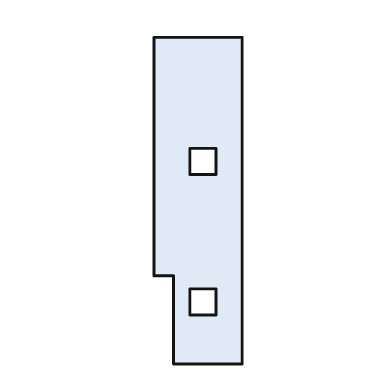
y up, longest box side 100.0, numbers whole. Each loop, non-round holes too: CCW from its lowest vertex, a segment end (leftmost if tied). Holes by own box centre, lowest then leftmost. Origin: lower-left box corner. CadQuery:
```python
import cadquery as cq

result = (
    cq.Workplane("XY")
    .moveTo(6.0, 0.0)
    .lineTo(27.0, 0.0)
    .lineTo(27.0, 100.0)
    .lineTo(0.0, 100.0)
    .lineTo(0.0, 27.0)
    .lineTo(6.0, 27.0)
    .close()
    .moveTo(11.0, 15.0)
    .lineTo(19.0, 15.0)
    .lineTo(19.0, 23.0)
    .lineTo(11.0, 23.0)
    .close()
    .moveTo(11.0, 58.0)
    .lineTo(19.0, 58.0)
    .lineTo(19.0, 66.0)
    .lineTo(11.0, 66.0)
    .close()
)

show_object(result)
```